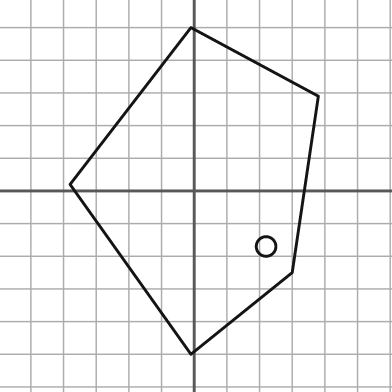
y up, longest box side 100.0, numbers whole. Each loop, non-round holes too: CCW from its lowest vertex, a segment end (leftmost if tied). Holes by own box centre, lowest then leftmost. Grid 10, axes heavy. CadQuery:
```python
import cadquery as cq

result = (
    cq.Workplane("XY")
    .moveTo(-1.0, -50.0)
    .lineTo(30.0, -25.0)
    .lineTo(38.0, 29.0)
    .lineTo(-1.0, 50.0)
    .lineTo(-38.0, 2.0)
    .close()
    .moveTo(22.0, -17.0)
    .circle(3.0)
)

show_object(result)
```